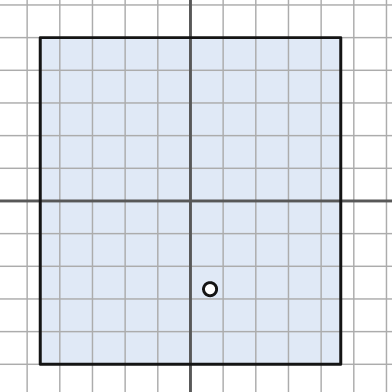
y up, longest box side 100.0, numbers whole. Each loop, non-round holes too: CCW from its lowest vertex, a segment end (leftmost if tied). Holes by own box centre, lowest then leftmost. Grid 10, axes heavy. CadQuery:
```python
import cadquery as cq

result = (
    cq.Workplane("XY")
    .moveTo(-46.0, -50.0)
    .lineTo(46.0, -50.0)
    .lineTo(46.0, 50.0)
    .lineTo(-46.0, 50.0)
    .close()
    .moveTo(6.0, -27.0)
    .circle(2.0)
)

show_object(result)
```